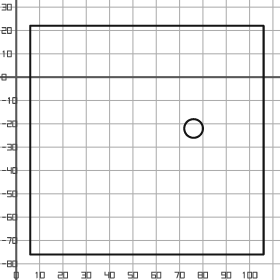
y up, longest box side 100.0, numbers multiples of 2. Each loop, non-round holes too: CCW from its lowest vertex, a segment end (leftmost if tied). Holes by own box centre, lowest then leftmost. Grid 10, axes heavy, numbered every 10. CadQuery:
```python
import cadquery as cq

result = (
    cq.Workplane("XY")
    .moveTo(6.0, -76.0)
    .lineTo(106.0, -76.0)
    .lineTo(106.0, 22.0)
    .lineTo(6.0, 22.0)
    .close()
    .moveTo(76.0, -22.0)
    .circle(4.0)
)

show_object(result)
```